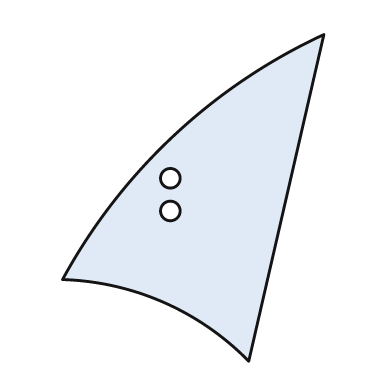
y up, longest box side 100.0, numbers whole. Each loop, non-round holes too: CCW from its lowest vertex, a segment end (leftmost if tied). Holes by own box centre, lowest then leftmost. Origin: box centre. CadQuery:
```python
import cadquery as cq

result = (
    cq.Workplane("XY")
    .moveTo(17.0, -50.0)
    .lineTo(40.0, 50.0)
    .threePointArc((-6.0, 19.0), (-40.0, -25.0))
    .threePointArc((-9.0, -32.0), (17.0, -50.0))
    .close()
    .moveTo(-7.0, -4.0)
    .circle(3.0)
    .moveTo(-7.0, 6.0)
    .circle(3.0)
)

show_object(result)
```